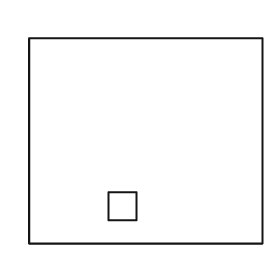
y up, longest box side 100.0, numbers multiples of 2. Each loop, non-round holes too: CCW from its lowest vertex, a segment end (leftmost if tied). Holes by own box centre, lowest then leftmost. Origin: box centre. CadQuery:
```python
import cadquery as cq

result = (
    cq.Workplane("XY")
    .moveTo(-50.0, -44.0)
    .lineTo(50.0, -44.0)
    .lineTo(50.0, 44.0)
    .lineTo(-50.0, 44.0)
    .close()
    .moveTo(-16.0, -34.0)
    .lineTo(-4.0, -34.0)
    .lineTo(-4.0, -22.0)
    .lineTo(-16.0, -22.0)
    .close()
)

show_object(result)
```